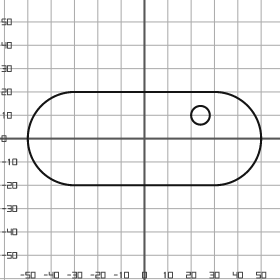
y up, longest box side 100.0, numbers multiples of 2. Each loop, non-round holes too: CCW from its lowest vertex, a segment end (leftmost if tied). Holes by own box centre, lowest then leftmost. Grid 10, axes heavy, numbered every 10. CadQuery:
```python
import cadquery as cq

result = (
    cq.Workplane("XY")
    .moveTo(-30.0, -20.0)
    .lineTo(30.0, -20.0)
    .threePointArc((50.0, 0.0), (30.0, 20.0))
    .lineTo(-30.0, 20.0)
    .threePointArc((-50.0, 0.0), (-30.0, -20.0))
    .close()
    .moveTo(24.0, 10.0)
    .circle(4.0)
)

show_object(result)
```